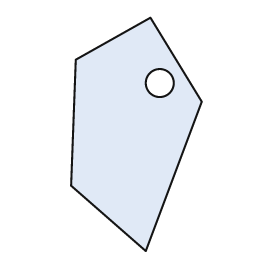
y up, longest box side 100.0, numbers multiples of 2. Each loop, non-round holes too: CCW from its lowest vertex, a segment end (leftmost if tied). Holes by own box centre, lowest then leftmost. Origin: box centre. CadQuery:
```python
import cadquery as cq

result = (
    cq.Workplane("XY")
    .moveTo(4.0, -50.0)
    .lineTo(28.0, 14.0)
    .lineTo(6.0, 50.0)
    .lineTo(-26.0, 32.0)
    .lineTo(-28.0, -22.0)
    .close()
    .moveTo(10.0, 22.0)
    .circle(6.0)
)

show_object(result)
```